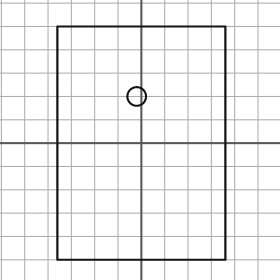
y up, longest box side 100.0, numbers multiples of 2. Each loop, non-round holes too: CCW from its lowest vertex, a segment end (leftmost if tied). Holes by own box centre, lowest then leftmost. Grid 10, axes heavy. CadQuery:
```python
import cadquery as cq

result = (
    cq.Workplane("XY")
    .moveTo(-36.0, -50.0)
    .lineTo(36.0, -50.0)
    .lineTo(36.0, 50.0)
    .lineTo(-36.0, 50.0)
    .close()
    .moveTo(-2.0, 20.0)
    .circle(4.0)
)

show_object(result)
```